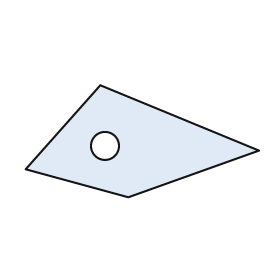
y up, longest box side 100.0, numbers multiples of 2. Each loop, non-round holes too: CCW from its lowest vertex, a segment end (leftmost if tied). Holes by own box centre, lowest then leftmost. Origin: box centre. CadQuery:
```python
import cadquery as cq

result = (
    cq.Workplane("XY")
    .moveTo(-6.0, -24.0)
    .lineTo(50.0, -4.0)
    .lineTo(-18.0, 24.0)
    .lineTo(-50.0, -12.0)
    .close()
    .moveTo(-16.0, -2.0)
    .circle(6.0)
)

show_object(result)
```